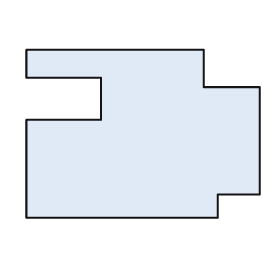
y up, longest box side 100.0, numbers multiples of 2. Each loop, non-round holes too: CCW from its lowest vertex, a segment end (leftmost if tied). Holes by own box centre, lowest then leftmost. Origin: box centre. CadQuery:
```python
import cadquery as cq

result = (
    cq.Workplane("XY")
    .moveTo(-50.0, -36.0)
    .lineTo(32.0, -36.0)
    .lineTo(32.0, -26.0)
    .lineTo(50.0, -26.0)
    .lineTo(50.0, 20.0)
    .lineTo(26.0, 20.0)
    .lineTo(26.0, 36.0)
    .lineTo(-50.0, 36.0)
    .lineTo(-50.0, 24.0)
    .lineTo(-18.0, 24.0)
    .lineTo(-18.0, 6.0)
    .lineTo(-50.0, 6.0)
    .close()
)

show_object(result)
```